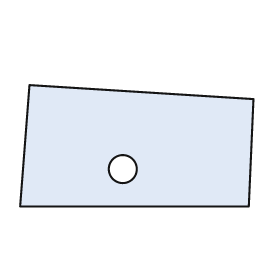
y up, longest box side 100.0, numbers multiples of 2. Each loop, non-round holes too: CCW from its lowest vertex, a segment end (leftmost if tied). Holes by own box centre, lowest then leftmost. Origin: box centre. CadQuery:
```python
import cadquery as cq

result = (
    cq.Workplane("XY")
    .moveTo(-50.0, -26.0)
    .lineTo(48.0, -26.0)
    .lineTo(50.0, 20.0)
    .lineTo(-46.0, 26.0)
    .close()
    .moveTo(-6.0, -10.0)
    .circle(6.0)
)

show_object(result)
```